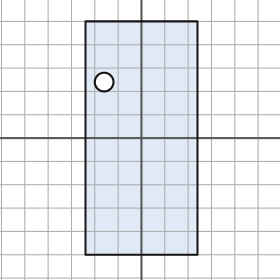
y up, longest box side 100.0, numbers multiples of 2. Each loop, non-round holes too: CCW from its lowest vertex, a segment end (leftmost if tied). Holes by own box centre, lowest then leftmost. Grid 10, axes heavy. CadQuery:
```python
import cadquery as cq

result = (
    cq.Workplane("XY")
    .moveTo(-24.0, -50.0)
    .lineTo(24.0, -50.0)
    .lineTo(24.0, 50.0)
    .lineTo(-24.0, 50.0)
    .close()
    .moveTo(-16.0, 24.0)
    .circle(4.0)
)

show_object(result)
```